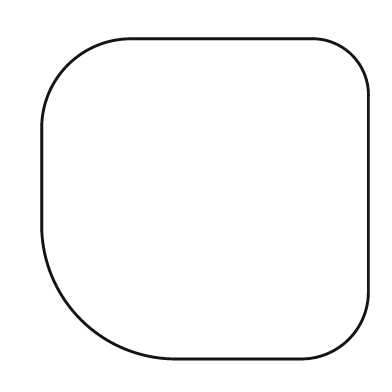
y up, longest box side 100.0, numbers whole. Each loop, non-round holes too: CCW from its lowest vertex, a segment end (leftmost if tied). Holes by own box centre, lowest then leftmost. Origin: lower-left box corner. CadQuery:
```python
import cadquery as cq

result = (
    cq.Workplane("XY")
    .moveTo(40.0, 0.0)
    .lineTo(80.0, 0.0)
    .threePointArc((94.0, 6.0), (100.0, 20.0))
    .lineTo(100.0, 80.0)
    .threePointArc((95.0, 93.0), (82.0, 98.0))
    .lineTo(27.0, 98.0)
    .threePointArc((8.0, 90.0), (0.0, 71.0))
    .lineTo(0.0, 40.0)
    .threePointArc((12.0, 12.0), (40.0, 0.0))
    .close()
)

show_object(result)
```